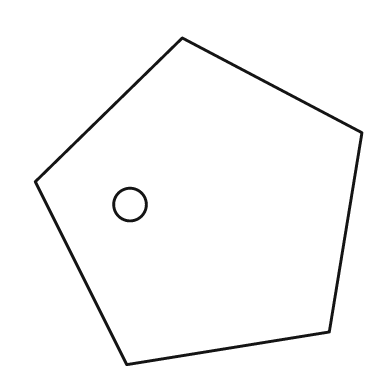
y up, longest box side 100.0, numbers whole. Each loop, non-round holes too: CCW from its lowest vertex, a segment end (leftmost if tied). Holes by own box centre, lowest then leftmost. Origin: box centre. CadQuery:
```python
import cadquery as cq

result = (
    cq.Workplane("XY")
    .moveTo(-22.0, -50.0)
    .lineTo(40.0, -40.0)
    .lineTo(50.0, 21.0)
    .lineTo(-5.0, 50.0)
    .lineTo(-50.0, 6.0)
    .close()
    .moveTo(-21.0, -1.0)
    .circle(5.0)
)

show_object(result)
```